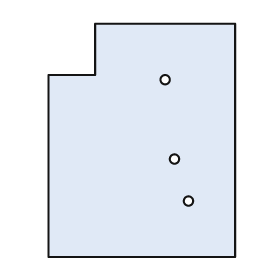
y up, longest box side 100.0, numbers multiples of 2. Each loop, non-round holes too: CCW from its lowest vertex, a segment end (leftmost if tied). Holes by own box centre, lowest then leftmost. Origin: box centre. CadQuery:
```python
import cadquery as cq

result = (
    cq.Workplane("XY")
    .moveTo(-40.0, -50.0)
    .lineTo(40.0, -50.0)
    .lineTo(40.0, 50.0)
    .lineTo(-20.0, 50.0)
    .lineTo(-20.0, 28.0)
    .lineTo(-40.0, 28.0)
    .close()
    .moveTo(20.0, -26.0)
    .circle(2.0)
    .moveTo(14.0, -8.0)
    .circle(2.0)
    .moveTo(10.0, 26.0)
    .circle(2.0)
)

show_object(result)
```